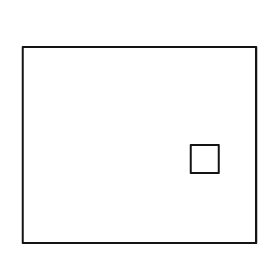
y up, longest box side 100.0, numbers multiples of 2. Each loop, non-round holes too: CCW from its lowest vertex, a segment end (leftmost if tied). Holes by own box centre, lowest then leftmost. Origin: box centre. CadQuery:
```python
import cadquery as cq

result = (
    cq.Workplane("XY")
    .moveTo(-50.0, -42.0)
    .lineTo(50.0, -42.0)
    .lineTo(50.0, 42.0)
    .lineTo(-50.0, 42.0)
    .close()
    .moveTo(22.0, -12.0)
    .lineTo(34.0, -12.0)
    .lineTo(34.0, 0.0)
    .lineTo(22.0, 0.0)
    .close()
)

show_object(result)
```